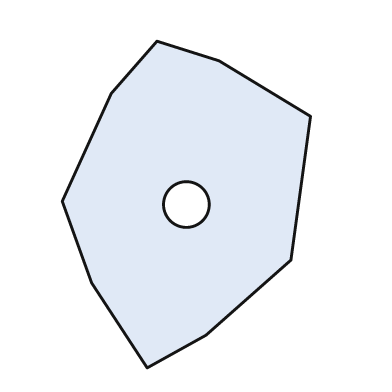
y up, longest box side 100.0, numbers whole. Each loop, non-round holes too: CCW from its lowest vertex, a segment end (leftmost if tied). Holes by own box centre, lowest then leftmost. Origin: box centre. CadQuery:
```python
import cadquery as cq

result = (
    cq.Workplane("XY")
    .moveTo(-12.0, -50.0)
    .lineTo(6.0, -40.0)
    .lineTo(32.0, -17.0)
    .lineTo(38.0, 27.0)
    .lineTo(10.0, 44.0)
    .lineTo(-9.0, 50.0)
    .lineTo(-23.0, 34.0)
    .lineTo(-38.0, 1.0)
    .lineTo(-29.0, -24.0)
    .close()
    .moveTo(0.0, 0.0)
    .circle(7.0)
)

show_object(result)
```